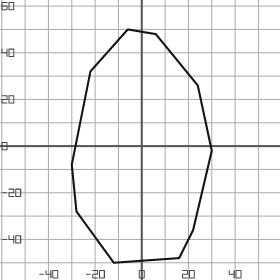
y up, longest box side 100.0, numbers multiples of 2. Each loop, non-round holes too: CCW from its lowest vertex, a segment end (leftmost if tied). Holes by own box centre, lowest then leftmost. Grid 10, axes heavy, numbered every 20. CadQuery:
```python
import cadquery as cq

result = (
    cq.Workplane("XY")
    .moveTo(-12.0, -50.0)
    .lineTo(16.0, -48.0)
    .lineTo(22.0, -36.0)
    .lineTo(30.0, -2.0)
    .lineTo(24.0, 26.0)
    .lineTo(6.0, 48.0)
    .lineTo(-6.0, 50.0)
    .lineTo(-22.0, 32.0)
    .lineTo(-30.0, -8.0)
    .lineTo(-28.0, -28.0)
    .close()
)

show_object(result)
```